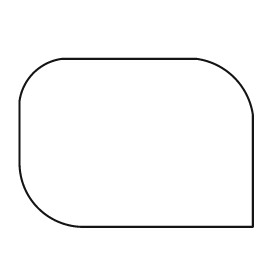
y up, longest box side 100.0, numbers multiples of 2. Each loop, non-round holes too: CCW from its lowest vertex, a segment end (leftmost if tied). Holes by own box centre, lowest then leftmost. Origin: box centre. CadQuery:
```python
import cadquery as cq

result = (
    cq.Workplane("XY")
    .moveTo(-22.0, -36.0)
    .lineTo(50.0, -36.0)
    .lineTo(50.0, 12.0)
    .threePointArc((42.0, 28.0), (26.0, 36.0))
    .lineTo(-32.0, 36.0)
    .threePointArc((-44.0, 30.0), (-50.0, 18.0))
    .lineTo(-50.0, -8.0)
    .threePointArc((-42.0, -28.0), (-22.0, -36.0))
    .close()
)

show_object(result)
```